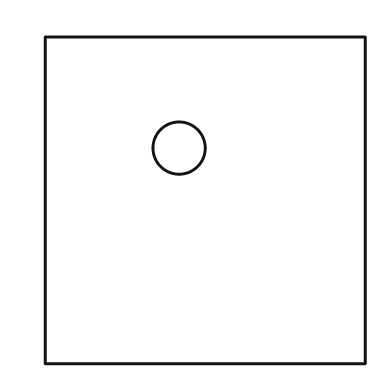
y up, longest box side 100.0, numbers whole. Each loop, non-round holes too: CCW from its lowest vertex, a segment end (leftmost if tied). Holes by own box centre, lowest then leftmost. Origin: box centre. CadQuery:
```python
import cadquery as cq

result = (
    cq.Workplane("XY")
    .moveTo(-49.0, -50.0)
    .lineTo(49.0, -50.0)
    .lineTo(49.0, 50.0)
    .lineTo(-49.0, 50.0)
    .close()
    .moveTo(-8.0, 16.0)
    .circle(8.0)
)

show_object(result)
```